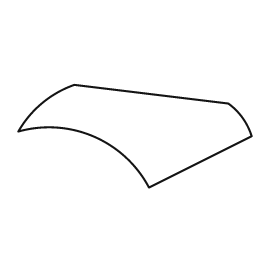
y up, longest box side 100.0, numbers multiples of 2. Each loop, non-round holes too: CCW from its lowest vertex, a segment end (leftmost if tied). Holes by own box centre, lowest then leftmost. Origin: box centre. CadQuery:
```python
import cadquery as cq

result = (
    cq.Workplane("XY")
    .moveTo(6.0, -22.0)
    .lineTo(50.0, 0.0)
    .threePointArc((46.0, 8.0), (40.0, 14.0))
    .lineTo(-26.0, 22.0)
    .threePointArc((-40.0, 14.0), (-50.0, 2.0))
    .threePointArc((-18.0, 0.0), (6.0, -22.0))
    .close()
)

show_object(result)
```